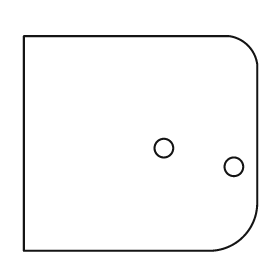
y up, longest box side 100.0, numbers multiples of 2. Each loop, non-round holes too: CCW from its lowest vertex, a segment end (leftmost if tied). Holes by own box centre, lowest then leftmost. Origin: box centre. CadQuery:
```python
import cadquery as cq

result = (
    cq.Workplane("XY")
    .moveTo(-50.0, -46.0)
    .lineTo(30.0, -46.0)
    .threePointArc((44.0, -40.0), (50.0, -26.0))
    .lineTo(50.0, 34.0)
    .threePointArc((46.0, 42.0), (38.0, 46.0))
    .lineTo(-50.0, 46.0)
    .close()
    .moveTo(40.0, -10.0)
    .circle(4.0)
    .moveTo(10.0, -2.0)
    .circle(4.0)
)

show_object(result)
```